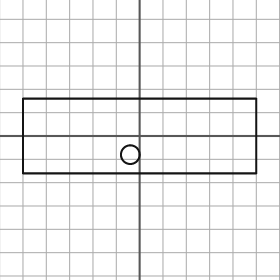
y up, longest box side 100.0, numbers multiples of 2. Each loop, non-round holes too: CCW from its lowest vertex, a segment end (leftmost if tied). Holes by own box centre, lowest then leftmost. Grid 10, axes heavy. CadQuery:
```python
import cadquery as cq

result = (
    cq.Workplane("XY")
    .moveTo(-50.0, -16.0)
    .lineTo(50.0, -16.0)
    .lineTo(50.0, 16.0)
    .lineTo(-50.0, 16.0)
    .close()
    .moveTo(-4.0, -8.0)
    .circle(4.0)
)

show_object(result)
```